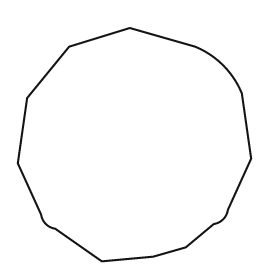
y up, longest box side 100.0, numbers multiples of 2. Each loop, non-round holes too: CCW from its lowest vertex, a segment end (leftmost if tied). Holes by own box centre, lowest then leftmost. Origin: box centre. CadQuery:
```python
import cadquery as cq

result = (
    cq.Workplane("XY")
    .moveTo(-14.0, -50.0)
    .lineTo(8.0, -48.0)
    .lineTo(22.0, -44.0)
    .lineTo(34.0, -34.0)
    .threePointArc((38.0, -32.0), (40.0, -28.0))
    .lineTo(50.0, -6.0)
    .lineTo(46.0, 22.0)
    .threePointArc((38.0, 34.0), (26.0, 42.0))
    .lineTo(-2.0, 50.0)
    .lineTo(-28.0, 42.0)
    .lineTo(-46.0, 20.0)
    .lineTo(-50.0, -8.0)
    .lineTo(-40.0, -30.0)
    .threePointArc((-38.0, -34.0), (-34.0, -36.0))
    .close()
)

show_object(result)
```